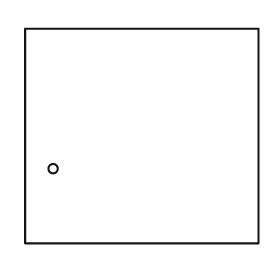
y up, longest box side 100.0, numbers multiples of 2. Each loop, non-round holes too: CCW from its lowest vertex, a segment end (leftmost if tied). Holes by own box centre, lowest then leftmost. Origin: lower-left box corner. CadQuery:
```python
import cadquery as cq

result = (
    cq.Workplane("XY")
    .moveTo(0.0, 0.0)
    .lineTo(100.0, 0.0)
    .lineTo(100.0, 92.0)
    .lineTo(0.0, 92.0)
    .close()
    .moveTo(12.0, 32.0)
    .circle(2.0)
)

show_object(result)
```